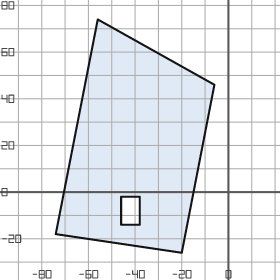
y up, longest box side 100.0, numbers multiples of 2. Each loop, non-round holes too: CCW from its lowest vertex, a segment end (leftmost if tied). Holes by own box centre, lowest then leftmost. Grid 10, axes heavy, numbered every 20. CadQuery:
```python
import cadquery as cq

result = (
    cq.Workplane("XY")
    .moveTo(-20.0, -26.0)
    .lineTo(-6.0, 46.0)
    .lineTo(-56.0, 74.0)
    .lineTo(-74.0, -18.0)
    .close()
    .moveTo(-46.0, -14.0)
    .lineTo(-38.0, -14.0)
    .lineTo(-38.0, -2.0)
    .lineTo(-46.0, -2.0)
    .close()
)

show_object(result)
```